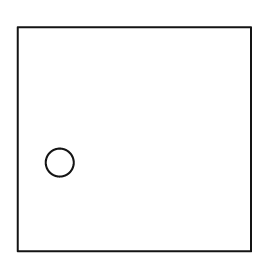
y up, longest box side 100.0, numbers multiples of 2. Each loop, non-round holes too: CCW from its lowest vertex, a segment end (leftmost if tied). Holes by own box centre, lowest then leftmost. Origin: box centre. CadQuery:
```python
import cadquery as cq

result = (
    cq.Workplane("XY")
    .moveTo(-50.0, -48.0)
    .lineTo(50.0, -48.0)
    .lineTo(50.0, 48.0)
    .lineTo(-50.0, 48.0)
    .close()
    .moveTo(-32.0, -10.0)
    .circle(6.0)
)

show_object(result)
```